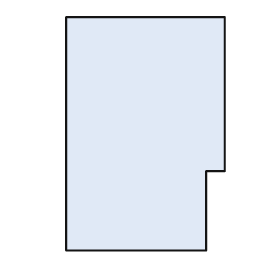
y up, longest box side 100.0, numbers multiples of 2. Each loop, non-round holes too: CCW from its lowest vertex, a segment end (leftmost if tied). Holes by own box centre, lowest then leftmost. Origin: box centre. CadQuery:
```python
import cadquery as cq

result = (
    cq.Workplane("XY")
    .moveTo(-34.0, -50.0)
    .lineTo(26.0, -50.0)
    .lineTo(26.0, -16.0)
    .lineTo(34.0, -16.0)
    .lineTo(34.0, 50.0)
    .lineTo(-34.0, 50.0)
    .close()
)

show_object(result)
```